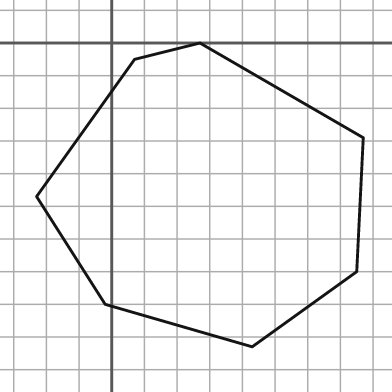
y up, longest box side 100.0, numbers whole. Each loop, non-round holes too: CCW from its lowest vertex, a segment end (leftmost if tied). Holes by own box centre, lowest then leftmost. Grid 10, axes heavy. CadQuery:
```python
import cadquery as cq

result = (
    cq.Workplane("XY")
    .moveTo(43.0, -93.0)
    .lineTo(75.0, -70.0)
    .lineTo(77.0, -29.0)
    .lineTo(27.0, 0.0)
    .lineTo(7.0, -5.0)
    .lineTo(-23.0, -47.0)
    .lineTo(-2.0, -80.0)
    .close()
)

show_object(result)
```